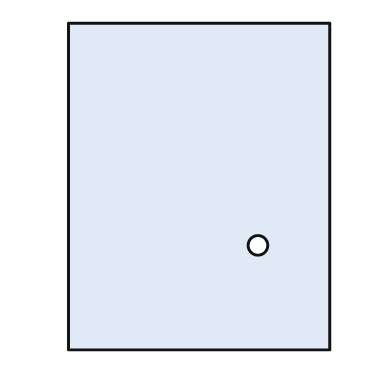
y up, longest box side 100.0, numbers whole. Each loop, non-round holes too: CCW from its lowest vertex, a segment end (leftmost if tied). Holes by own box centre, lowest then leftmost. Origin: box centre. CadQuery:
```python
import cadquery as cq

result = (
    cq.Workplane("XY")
    .moveTo(-40.0, -50.0)
    .lineTo(40.0, -50.0)
    .lineTo(40.0, 50.0)
    .lineTo(-40.0, 50.0)
    .close()
    .moveTo(18.0, -18.0)
    .circle(3.0)
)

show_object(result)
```